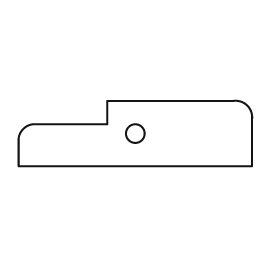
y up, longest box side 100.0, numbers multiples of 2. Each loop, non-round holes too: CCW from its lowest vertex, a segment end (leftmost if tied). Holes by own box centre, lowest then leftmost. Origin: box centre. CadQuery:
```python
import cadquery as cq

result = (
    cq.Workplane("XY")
    .moveTo(-50.0, -14.0)
    .lineTo(50.0, -14.0)
    .lineTo(50.0, 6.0)
    .threePointArc((48.0, 12.0), (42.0, 14.0))
    .lineTo(-12.0, 14.0)
    .lineTo(-12.0, 4.0)
    .lineTo(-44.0, 4.0)
    .threePointArc((-48.0, 2.0), (-50.0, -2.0))
    .close()
    .moveTo(0.0, 0.0)
    .circle(4.0)
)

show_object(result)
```